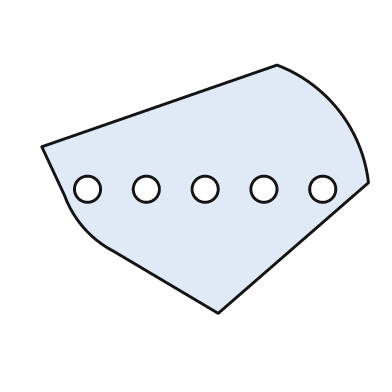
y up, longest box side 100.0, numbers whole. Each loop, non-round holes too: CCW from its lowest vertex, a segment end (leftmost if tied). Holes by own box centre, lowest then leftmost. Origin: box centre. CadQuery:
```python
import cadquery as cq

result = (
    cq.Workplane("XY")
    .moveTo(4.0, -38.0)
    .lineTo(50.0, 2.0)
    .threePointArc((41.0, 24.0), (22.0, 38.0))
    .lineTo(-50.0, 13.0)
    .lineTo(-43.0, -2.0)
    .threePointArc((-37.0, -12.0), (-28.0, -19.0))
    .close()
    .moveTo(-36.0, 0.0)
    .circle(4.0)
    .moveTo(-18.0, 0.0)
    .circle(4.0)
    .moveTo(0.0, 0.0)
    .circle(4.0)
    .moveTo(18.0, 0.0)
    .circle(4.0)
    .moveTo(36.0, 0.0)
    .circle(4.0)
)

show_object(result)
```